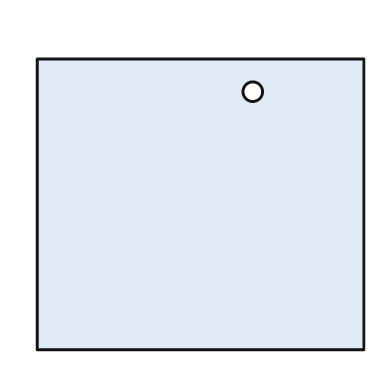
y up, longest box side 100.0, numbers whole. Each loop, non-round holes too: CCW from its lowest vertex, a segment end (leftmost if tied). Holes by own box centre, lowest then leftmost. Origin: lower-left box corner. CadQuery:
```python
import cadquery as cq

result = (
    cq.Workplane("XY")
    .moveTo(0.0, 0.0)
    .lineTo(100.0, 0.0)
    .lineTo(100.0, 89.0)
    .lineTo(0.0, 89.0)
    .close()
    .moveTo(66.0, 79.0)
    .circle(3.0)
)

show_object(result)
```